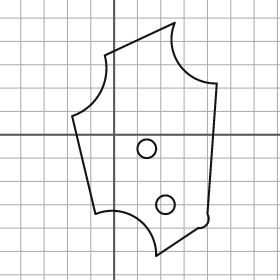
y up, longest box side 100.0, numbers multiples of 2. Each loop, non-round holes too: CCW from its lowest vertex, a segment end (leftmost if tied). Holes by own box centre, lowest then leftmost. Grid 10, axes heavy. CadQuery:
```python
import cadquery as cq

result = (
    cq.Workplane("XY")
    .moveTo(18.0, -52.0)
    .lineTo(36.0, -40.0)
    .threePointArc((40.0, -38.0), (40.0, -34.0))
    .lineTo(44.0, 22.0)
    .threePointArc((28.0, 30.0), (26.0, 48.0))
    .lineTo(-4.0, 34.0)
    .threePointArc((-6.0, 18.0), (-18.0, 8.0))
    .lineTo(-8.0, -34.0)
    .threePointArc((10.0, -36.0), (18.0, -52.0))
    .close()
    .moveTo(22.0, -30.0)
    .circle(4.0)
    .moveTo(14.0, -6.0)
    .circle(4.0)
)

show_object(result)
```